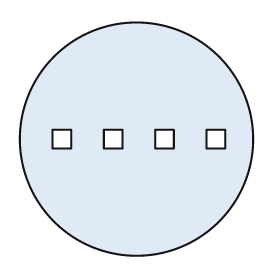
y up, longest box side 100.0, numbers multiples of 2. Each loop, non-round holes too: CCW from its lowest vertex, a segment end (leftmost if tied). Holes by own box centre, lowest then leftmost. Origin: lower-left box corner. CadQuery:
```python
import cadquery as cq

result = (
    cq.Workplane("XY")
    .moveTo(50.0, 50.0)
    .circle(50.0)
    .moveTo(14.0, 46.0)
    .lineTo(22.0, 46.0)
    .lineTo(22.0, 54.0)
    .lineTo(14.0, 54.0)
    .close()
    .moveTo(36.0, 46.0)
    .lineTo(44.0, 46.0)
    .lineTo(44.0, 54.0)
    .lineTo(36.0, 54.0)
    .close()
    .moveTo(58.0, 46.0)
    .lineTo(66.0, 46.0)
    .lineTo(66.0, 54.0)
    .lineTo(58.0, 54.0)
    .close()
    .moveTo(80.0, 46.0)
    .lineTo(88.0, 46.0)
    .lineTo(88.0, 54.0)
    .lineTo(80.0, 54.0)
    .close()
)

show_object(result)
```